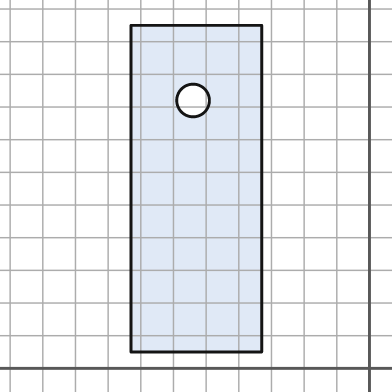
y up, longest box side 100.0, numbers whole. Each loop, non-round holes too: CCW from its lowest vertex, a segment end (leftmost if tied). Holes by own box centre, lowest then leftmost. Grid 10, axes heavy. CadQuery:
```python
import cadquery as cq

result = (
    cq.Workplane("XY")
    .moveTo(-73.0, 5.0)
    .lineTo(-33.0, 5.0)
    .lineTo(-33.0, 105.0)
    .lineTo(-73.0, 105.0)
    .close()
    .moveTo(-54.0, 82.0)
    .circle(5.0)
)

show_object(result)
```